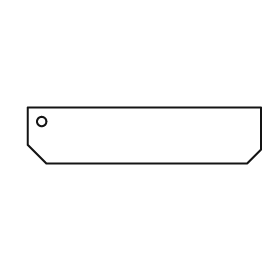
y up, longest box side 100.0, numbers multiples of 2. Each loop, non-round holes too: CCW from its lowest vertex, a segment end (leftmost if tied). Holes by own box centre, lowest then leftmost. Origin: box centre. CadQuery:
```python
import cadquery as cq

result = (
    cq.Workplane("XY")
    .moveTo(-42.0, -12.0)
    .lineTo(44.0, -12.0)
    .lineTo(50.0, -6.0)
    .lineTo(50.0, 12.0)
    .lineTo(-50.0, 12.0)
    .lineTo(-50.0, -4.0)
    .close()
    .moveTo(-44.0, 6.0)
    .circle(2.0)
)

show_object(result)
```